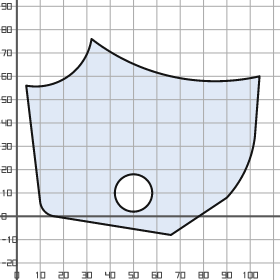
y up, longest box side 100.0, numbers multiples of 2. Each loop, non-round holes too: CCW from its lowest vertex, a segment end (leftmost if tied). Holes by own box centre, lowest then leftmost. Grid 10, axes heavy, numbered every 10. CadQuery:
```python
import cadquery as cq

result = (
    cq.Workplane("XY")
    .moveTo(66.0, -8.0)
    .lineTo(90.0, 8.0)
    .threePointArc((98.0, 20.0), (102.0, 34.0))
    .lineTo(104.0, 60.0)
    .threePointArc((66.0, 60.0), (32.0, 76.0))
    .threePointArc((22.0, 60.0), (4.0, 56.0))
    .lineTo(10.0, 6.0)
    .threePointArc((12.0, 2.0), (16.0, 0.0))
    .close()
    .moveTo(50.0, 10.0)
    .circle(8.0)
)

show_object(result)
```